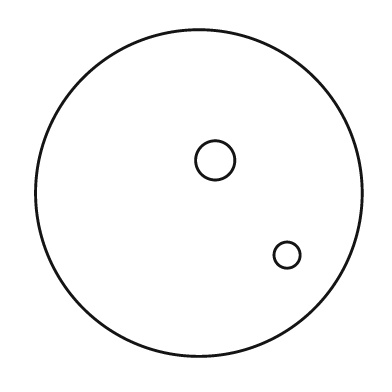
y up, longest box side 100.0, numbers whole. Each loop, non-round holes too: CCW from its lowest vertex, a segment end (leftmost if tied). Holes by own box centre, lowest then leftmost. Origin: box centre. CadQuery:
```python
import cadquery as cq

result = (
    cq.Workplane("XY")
    .moveTo(0.0, 0.0)
    .circle(50.0)
    .moveTo(27.0, -19.0)
    .circle(4.0)
    .moveTo(5.0, 10.0)
    .circle(6.0)
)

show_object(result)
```